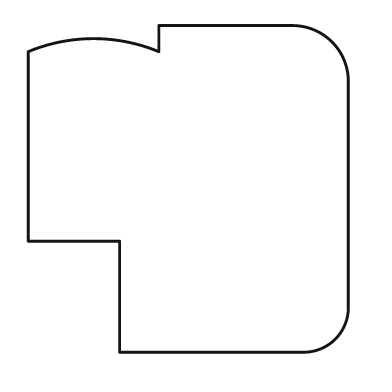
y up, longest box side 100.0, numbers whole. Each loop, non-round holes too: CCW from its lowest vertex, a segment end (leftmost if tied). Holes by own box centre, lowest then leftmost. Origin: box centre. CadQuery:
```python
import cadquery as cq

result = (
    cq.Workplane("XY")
    .moveTo(-21.0, -50.0)
    .lineTo(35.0, -50.0)
    .threePointArc((45.0, -46.0), (49.0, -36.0))
    .lineTo(49.0, 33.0)
    .threePointArc((44.0, 45.0), (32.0, 50.0))
    .lineTo(-9.0, 50.0)
    .lineTo(-9.0, 42.0)
    .threePointArc((-29.0, 46.0), (-49.0, 42.0))
    .lineTo(-49.0, -16.0)
    .lineTo(-21.0, -16.0)
    .close()
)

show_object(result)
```